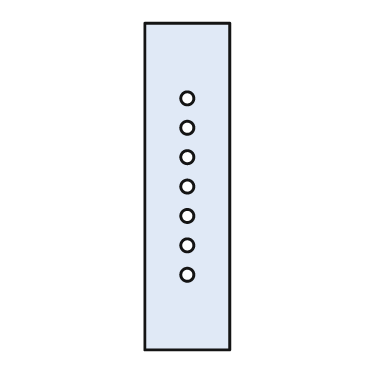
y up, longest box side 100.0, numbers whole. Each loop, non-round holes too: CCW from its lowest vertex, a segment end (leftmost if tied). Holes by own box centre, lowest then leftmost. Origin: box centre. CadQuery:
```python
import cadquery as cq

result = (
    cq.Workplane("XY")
    .moveTo(-13.0, -50.0)
    .lineTo(13.0, -50.0)
    .lineTo(13.0, 50.0)
    .lineTo(-13.0, 50.0)
    .close()
    .moveTo(0.0, -27.0)
    .circle(2.0)
    .moveTo(0.0, -18.0)
    .circle(2.0)
    .moveTo(0.0, -9.0)
    .circle(2.0)
    .moveTo(0.0, 0.0)
    .circle(2.0)
    .moveTo(0.0, 9.0)
    .circle(2.0)
    .moveTo(0.0, 18.0)
    .circle(2.0)
    .moveTo(0.0, 27.0)
    .circle(2.0)
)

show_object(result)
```